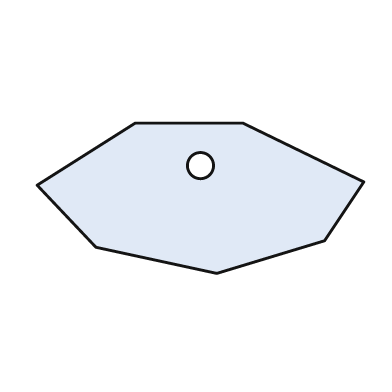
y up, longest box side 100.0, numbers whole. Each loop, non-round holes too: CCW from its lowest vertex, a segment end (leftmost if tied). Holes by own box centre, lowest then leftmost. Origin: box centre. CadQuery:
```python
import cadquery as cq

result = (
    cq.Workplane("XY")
    .moveTo(5.0, -23.0)
    .lineTo(38.0, -13.0)
    .lineTo(50.0, 5.0)
    .lineTo(13.0, 23.0)
    .lineTo(-20.0, 23.0)
    .lineTo(-50.0, 4.0)
    .lineTo(-32.0, -15.0)
    .close()
    .moveTo(0.0, 10.0)
    .circle(4.0)
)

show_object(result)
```